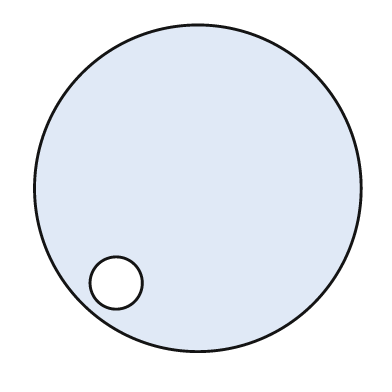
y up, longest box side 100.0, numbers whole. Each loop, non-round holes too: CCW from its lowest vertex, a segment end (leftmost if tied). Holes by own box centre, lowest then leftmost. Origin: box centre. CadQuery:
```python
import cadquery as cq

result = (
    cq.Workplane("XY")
    .moveTo(0.0, 0.0)
    .circle(50.0)
    .moveTo(-25.0, -29.0)
    .circle(8.0)
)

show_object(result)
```